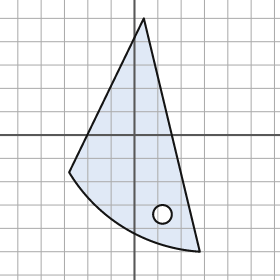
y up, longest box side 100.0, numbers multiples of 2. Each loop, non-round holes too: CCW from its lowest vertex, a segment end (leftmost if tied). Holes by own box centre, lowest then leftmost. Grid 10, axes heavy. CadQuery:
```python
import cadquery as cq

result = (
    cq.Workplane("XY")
    .moveTo(28.0, -50.0)
    .lineTo(4.0, 50.0)
    .lineTo(-28.0, -16.0)
    .threePointArc((-4.0, -40.0), (28.0, -50.0))
    .close()
    .moveTo(12.0, -34.0)
    .circle(4.0)
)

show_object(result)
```